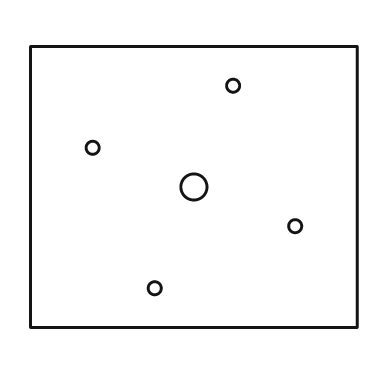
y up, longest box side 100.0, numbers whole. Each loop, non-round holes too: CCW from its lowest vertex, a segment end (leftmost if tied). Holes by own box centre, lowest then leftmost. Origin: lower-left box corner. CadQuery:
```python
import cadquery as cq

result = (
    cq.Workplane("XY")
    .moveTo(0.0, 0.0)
    .lineTo(100.0, 0.0)
    .lineTo(100.0, 86.0)
    .lineTo(0.0, 86.0)
    .close()
    .moveTo(38.0, 12.0)
    .circle(2.0)
    .moveTo(81.0, 31.0)
    .circle(2.0)
    .moveTo(50.0, 43.0)
    .circle(4.0)
    .moveTo(19.0, 55.0)
    .circle(2.0)
    .moveTo(62.0, 74.0)
    .circle(2.0)
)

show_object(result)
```